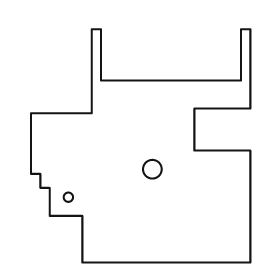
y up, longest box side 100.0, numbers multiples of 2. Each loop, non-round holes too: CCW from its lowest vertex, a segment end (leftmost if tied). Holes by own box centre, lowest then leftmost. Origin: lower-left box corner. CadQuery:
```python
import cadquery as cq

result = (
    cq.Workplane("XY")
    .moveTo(22.0, 0.0)
    .lineTo(94.0, 0.0)
    .lineTo(94.0, 48.0)
    .lineTo(70.0, 48.0)
    .lineTo(70.0, 66.0)
    .lineTo(94.0, 66.0)
    .lineTo(94.0, 100.0)
    .lineTo(90.0, 100.0)
    .lineTo(90.0, 78.0)
    .lineTo(30.0, 78.0)
    .lineTo(30.0, 100.0)
    .lineTo(26.0, 100.0)
    .lineTo(26.0, 64.0)
    .lineTo(0.0, 64.0)
    .lineTo(0.0, 38.0)
    .lineTo(4.0, 38.0)
    .lineTo(4.0, 32.0)
    .lineTo(8.0, 32.0)
    .lineTo(8.0, 20.0)
    .lineTo(22.0, 20.0)
    .close()
    .moveTo(16.0, 28.0)
    .circle(2.0)
    .moveTo(52.0, 40.0)
    .circle(4.0)
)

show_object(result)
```